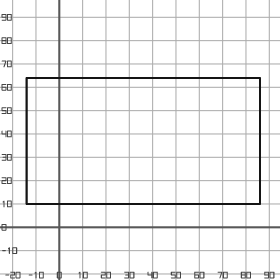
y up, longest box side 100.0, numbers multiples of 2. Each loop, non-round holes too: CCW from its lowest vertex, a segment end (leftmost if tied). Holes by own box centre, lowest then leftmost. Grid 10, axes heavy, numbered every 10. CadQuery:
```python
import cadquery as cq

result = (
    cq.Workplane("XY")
    .moveTo(-14.0, 10.0)
    .lineTo(86.0, 10.0)
    .lineTo(86.0, 64.0)
    .lineTo(-14.0, 64.0)
    .close()
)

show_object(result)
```